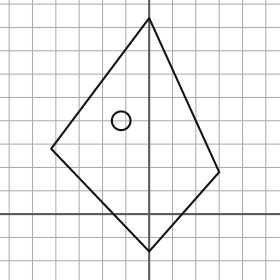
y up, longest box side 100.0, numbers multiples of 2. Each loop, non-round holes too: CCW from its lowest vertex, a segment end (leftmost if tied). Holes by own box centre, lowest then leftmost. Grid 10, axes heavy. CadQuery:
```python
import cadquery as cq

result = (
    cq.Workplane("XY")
    .moveTo(0.0, -16.0)
    .lineTo(30.0, 18.0)
    .lineTo(0.0, 84.0)
    .lineTo(-42.0, 28.0)
    .close()
    .moveTo(-12.0, 40.0)
    .circle(4.0)
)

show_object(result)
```